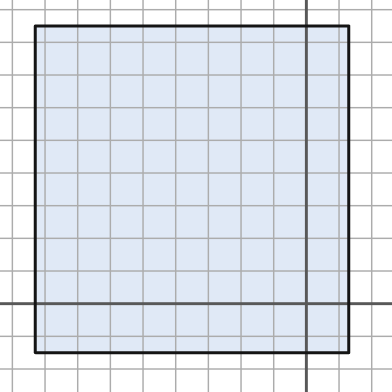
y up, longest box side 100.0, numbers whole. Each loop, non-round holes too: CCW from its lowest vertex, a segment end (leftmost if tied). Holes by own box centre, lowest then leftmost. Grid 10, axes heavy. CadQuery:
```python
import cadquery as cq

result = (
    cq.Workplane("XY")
    .moveTo(-83.0, -15.0)
    .lineTo(13.0, -15.0)
    .lineTo(13.0, 85.0)
    .lineTo(-83.0, 85.0)
    .close()
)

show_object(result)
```